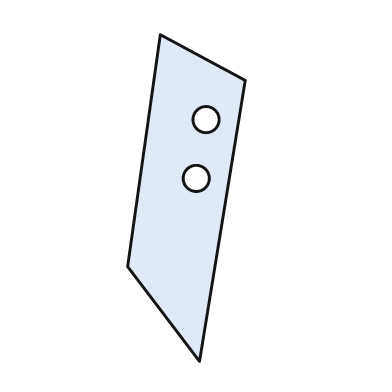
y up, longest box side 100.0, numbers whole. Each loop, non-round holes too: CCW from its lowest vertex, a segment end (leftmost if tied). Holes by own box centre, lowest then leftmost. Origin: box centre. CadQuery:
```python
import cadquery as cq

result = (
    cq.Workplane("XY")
    .moveTo(4.0, -50.0)
    .lineTo(18.0, 36.0)
    .lineTo(-8.0, 50.0)
    .lineTo(-18.0, -21.0)
    .close()
    .moveTo(3.0, 6.0)
    .circle(4.0)
    .moveTo(6.0, 24.0)
    .circle(4.0)
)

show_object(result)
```